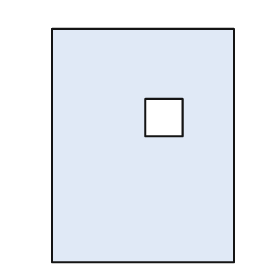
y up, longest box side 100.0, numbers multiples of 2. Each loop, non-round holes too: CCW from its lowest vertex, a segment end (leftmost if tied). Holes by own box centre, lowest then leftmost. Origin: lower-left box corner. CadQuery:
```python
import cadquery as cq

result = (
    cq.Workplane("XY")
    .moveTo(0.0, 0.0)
    .lineTo(78.0, 0.0)
    .lineTo(78.0, 100.0)
    .lineTo(0.0, 100.0)
    .close()
    .moveTo(40.0, 54.0)
    .lineTo(56.0, 54.0)
    .lineTo(56.0, 70.0)
    .lineTo(40.0, 70.0)
    .close()
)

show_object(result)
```